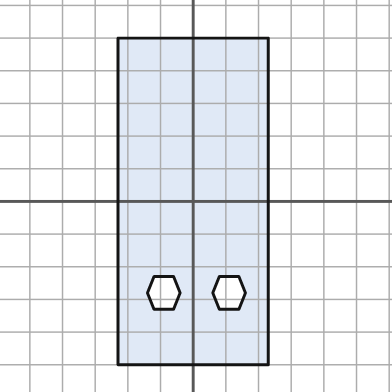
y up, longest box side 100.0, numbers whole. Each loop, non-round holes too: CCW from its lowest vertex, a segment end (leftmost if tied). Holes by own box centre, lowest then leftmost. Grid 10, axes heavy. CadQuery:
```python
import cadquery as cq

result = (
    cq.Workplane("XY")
    .moveTo(-23.0, -50.0)
    .lineTo(23.0, -50.0)
    .lineTo(23.0, 50.0)
    .lineTo(-23.0, 50.0)
    .close()
    .moveTo(-12.0, -33.0)
    .lineTo(-6.0, -33.0)
    .lineTo(-4.0, -28.0)
    .lineTo(-6.0, -23.0)
    .lineTo(-12.0, -23.0)
    .lineTo(-14.0, -28.0)
    .close()
    .moveTo(8.0, -33.0)
    .lineTo(14.0, -33.0)
    .lineTo(16.0, -28.0)
    .lineTo(14.0, -23.0)
    .lineTo(8.0, -23.0)
    .lineTo(6.0, -28.0)
    .close()
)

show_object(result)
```